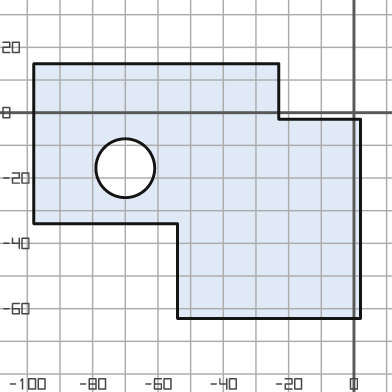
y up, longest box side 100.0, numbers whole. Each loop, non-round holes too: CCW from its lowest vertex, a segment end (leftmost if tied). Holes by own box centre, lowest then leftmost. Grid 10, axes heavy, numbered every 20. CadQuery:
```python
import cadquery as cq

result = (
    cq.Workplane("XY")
    .moveTo(-54.0, -63.0)
    .lineTo(2.0, -63.0)
    .lineTo(2.0, -2.0)
    .lineTo(-23.0, -2.0)
    .lineTo(-23.0, 15.0)
    .lineTo(-98.0, 15.0)
    .lineTo(-98.0, -34.0)
    .lineTo(-54.0, -34.0)
    .close()
    .moveTo(-70.0, -17.0)
    .circle(9.0)
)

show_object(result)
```